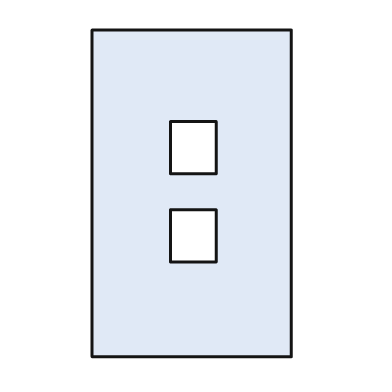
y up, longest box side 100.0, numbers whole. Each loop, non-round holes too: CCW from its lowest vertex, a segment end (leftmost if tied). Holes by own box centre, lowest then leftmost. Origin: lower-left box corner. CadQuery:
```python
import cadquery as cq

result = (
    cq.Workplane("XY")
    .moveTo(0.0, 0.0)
    .lineTo(61.0, 0.0)
    .lineTo(61.0, 100.0)
    .lineTo(0.0, 100.0)
    .close()
    .moveTo(24.0, 29.0)
    .lineTo(38.0, 29.0)
    .lineTo(38.0, 45.0)
    .lineTo(24.0, 45.0)
    .close()
    .moveTo(24.0, 56.0)
    .lineTo(38.0, 56.0)
    .lineTo(38.0, 72.0)
    .lineTo(24.0, 72.0)
    .close()
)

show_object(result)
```